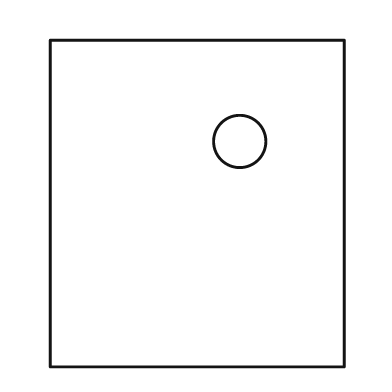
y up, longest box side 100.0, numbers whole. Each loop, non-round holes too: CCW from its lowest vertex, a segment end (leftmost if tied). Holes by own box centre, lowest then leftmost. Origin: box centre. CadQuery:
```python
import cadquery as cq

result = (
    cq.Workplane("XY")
    .moveTo(-45.0, -50.0)
    .lineTo(45.0, -50.0)
    .lineTo(45.0, 50.0)
    .lineTo(-45.0, 50.0)
    .close()
    .moveTo(13.0, 19.0)
    .circle(8.0)
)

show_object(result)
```